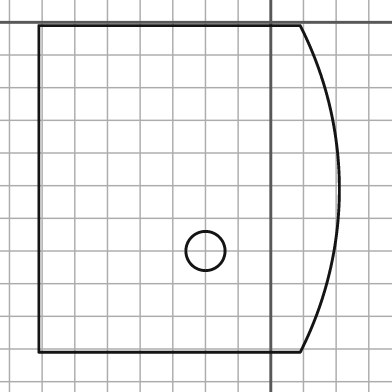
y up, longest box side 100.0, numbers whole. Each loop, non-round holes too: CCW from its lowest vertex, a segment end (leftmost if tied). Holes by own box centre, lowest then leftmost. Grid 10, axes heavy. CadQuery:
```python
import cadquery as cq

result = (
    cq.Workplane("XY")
    .moveTo(-71.0, -101.0)
    .lineTo(9.0, -101.0)
    .threePointArc((21.0, -51.0), (9.0, -1.0))
    .lineTo(-71.0, -1.0)
    .close()
    .moveTo(-20.0, -70.0)
    .circle(6.0)
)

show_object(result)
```